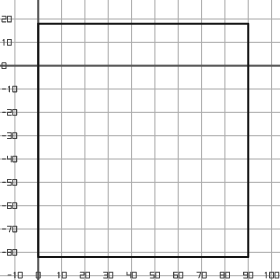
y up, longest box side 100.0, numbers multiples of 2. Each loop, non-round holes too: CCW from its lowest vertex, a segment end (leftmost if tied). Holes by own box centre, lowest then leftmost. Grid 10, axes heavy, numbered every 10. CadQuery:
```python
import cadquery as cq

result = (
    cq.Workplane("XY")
    .moveTo(0.0, -82.0)
    .lineTo(90.0, -82.0)
    .lineTo(90.0, 18.0)
    .lineTo(0.0, 18.0)
    .close()
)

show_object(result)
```